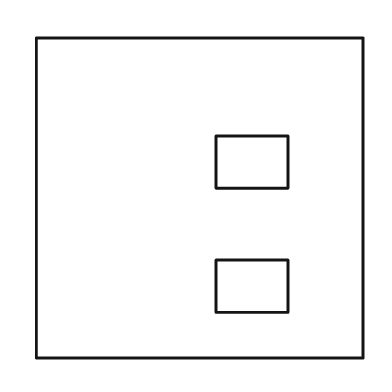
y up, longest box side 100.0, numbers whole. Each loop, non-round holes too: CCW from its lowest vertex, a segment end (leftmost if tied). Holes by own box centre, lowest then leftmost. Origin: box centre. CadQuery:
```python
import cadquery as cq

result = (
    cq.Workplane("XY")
    .moveTo(-50.0, -49.0)
    .lineTo(50.0, -49.0)
    .lineTo(50.0, 49.0)
    .lineTo(-50.0, 49.0)
    .close()
    .moveTo(5.0, -35.0)
    .lineTo(27.0, -35.0)
    .lineTo(27.0, -19.0)
    .lineTo(5.0, -19.0)
    .close()
    .moveTo(5.0, 3.0)
    .lineTo(27.0, 3.0)
    .lineTo(27.0, 19.0)
    .lineTo(5.0, 19.0)
    .close()
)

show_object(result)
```